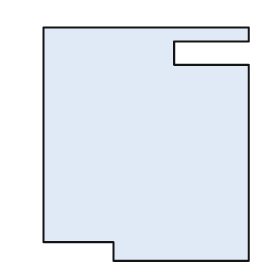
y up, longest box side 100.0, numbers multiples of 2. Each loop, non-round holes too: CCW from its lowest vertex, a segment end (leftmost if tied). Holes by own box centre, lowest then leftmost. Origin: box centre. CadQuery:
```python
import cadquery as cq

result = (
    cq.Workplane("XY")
    .moveTo(-14.0, -50.0)
    .lineTo(44.0, -50.0)
    .lineTo(44.0, 34.0)
    .lineTo(12.0, 34.0)
    .lineTo(12.0, 44.0)
    .lineTo(44.0, 44.0)
    .lineTo(44.0, 50.0)
    .lineTo(-44.0, 50.0)
    .lineTo(-44.0, -42.0)
    .lineTo(-14.0, -42.0)
    .close()
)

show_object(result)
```